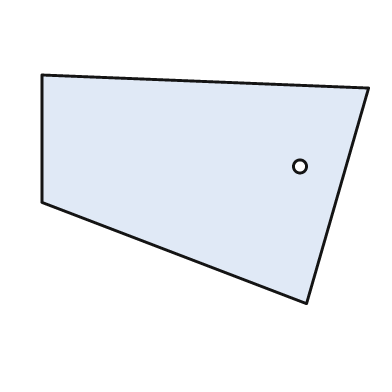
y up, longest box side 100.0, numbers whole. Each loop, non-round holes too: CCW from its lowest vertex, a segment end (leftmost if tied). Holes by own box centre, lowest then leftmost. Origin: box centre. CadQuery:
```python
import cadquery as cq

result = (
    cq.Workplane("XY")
    .moveTo(31.0, -35.0)
    .lineTo(50.0, 31.0)
    .lineTo(-50.0, 35.0)
    .lineTo(-50.0, -4.0)
    .close()
    .moveTo(29.0, 7.0)
    .circle(2.0)
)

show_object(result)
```